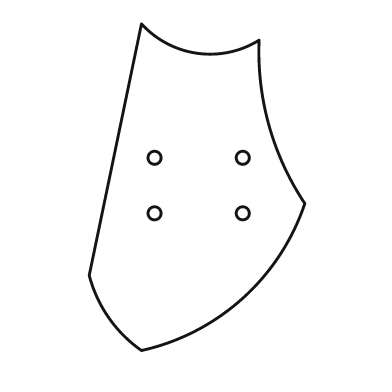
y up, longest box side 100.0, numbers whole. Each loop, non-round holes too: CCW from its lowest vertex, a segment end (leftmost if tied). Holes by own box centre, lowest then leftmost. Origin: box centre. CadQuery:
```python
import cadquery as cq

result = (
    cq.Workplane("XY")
    .moveTo(-17.0, -50.0)
    .threePointArc((14.0, -34.0), (33.0, -5.0))
    .threePointArc((22.0, 19.0), (19.0, 45.0))
    .threePointArc((0.0, 41.0), (-17.0, 50.0))
    .lineTo(-33.0, -27.0)
    .threePointArc((-27.0, -40.0), (-17.0, -50.0))
    .close()
    .moveTo(-13.0, -8.0)
    .circle(2.0)
    .moveTo(14.0, -8.0)
    .circle(2.0)
    .moveTo(-13.0, 9.0)
    .circle(2.0)
    .moveTo(14.0, 9.0)
    .circle(2.0)
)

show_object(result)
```